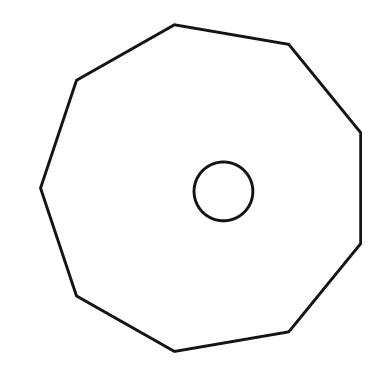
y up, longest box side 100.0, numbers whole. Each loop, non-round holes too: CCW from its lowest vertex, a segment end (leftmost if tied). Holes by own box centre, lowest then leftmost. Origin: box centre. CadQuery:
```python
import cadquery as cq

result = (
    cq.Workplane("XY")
    .moveTo(-8.0, -50.0)
    .lineTo(27.0, -44.0)
    .lineTo(49.0, -17.0)
    .lineTo(49.0, 17.0)
    .lineTo(27.0, 44.0)
    .lineTo(-8.0, 50.0)
    .lineTo(-38.0, 33.0)
    .lineTo(-49.0, 0.0)
    .lineTo(-38.0, -33.0)
    .close()
    .moveTo(7.0, -1.0)
    .circle(9.0)
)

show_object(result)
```